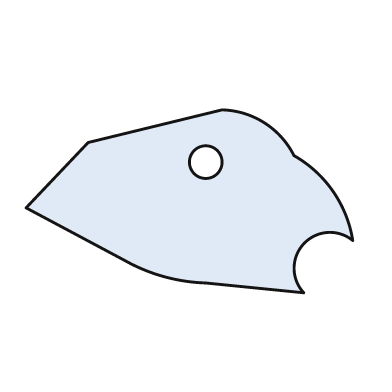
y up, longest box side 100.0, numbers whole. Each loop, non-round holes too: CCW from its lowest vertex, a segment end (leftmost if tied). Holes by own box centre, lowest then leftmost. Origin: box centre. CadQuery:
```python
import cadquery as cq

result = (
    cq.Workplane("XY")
    .moveTo(35.0, -28.0)
    .threePointArc((35.0, -13.0), (50.0, -12.0))
    .threePointArc((44.0, 3.0), (32.0, 14.0))
    .threePointArc((23.0, 24.0), (10.0, 28.0))
    .lineTo(-31.0, 18.0)
    .lineTo(-50.0, -2.0)
    .lineTo(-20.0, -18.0)
    .threePointArc((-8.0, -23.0), (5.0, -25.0))
    .close()
    .moveTo(5.0, 12.0)
    .circle(5.0)
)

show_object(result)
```